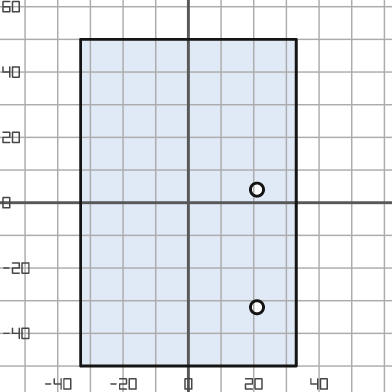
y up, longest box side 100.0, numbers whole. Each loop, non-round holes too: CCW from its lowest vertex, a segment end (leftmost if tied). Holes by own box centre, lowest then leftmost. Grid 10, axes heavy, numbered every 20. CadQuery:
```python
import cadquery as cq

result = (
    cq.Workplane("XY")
    .moveTo(-33.0, -50.0)
    .lineTo(33.0, -50.0)
    .lineTo(33.0, 50.0)
    .lineTo(-33.0, 50.0)
    .close()
    .moveTo(21.0, -32.0)
    .circle(2.0)
    .moveTo(21.0, 4.0)
    .circle(2.0)
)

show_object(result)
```